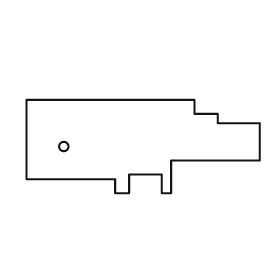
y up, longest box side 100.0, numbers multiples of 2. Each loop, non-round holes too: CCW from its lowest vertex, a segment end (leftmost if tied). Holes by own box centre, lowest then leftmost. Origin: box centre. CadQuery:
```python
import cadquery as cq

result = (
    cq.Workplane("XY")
    .moveTo(-12.0, -20.0)
    .lineTo(-6.0, -20.0)
    .lineTo(-6.0, -12.0)
    .lineTo(8.0, -12.0)
    .lineTo(8.0, -20.0)
    .lineTo(12.0, -20.0)
    .lineTo(12.0, -6.0)
    .lineTo(50.0, -6.0)
    .lineTo(50.0, 10.0)
    .lineTo(32.0, 10.0)
    .lineTo(32.0, 14.0)
    .lineTo(22.0, 14.0)
    .lineTo(22.0, 20.0)
    .lineTo(-50.0, 20.0)
    .lineTo(-50.0, -14.0)
    .lineTo(-12.0, -14.0)
    .close()
    .moveTo(-34.0, 0.0)
    .circle(2.0)
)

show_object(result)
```